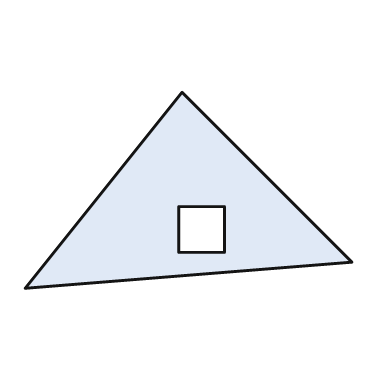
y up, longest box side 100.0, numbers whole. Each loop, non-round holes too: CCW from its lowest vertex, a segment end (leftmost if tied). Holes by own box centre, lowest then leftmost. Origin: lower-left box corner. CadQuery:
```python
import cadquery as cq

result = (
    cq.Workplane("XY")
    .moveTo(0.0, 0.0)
    .lineTo(100.0, 8.0)
    .lineTo(48.0, 60.0)
    .close()
    .moveTo(47.0, 11.0)
    .lineTo(61.0, 11.0)
    .lineTo(61.0, 25.0)
    .lineTo(47.0, 25.0)
    .close()
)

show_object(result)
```